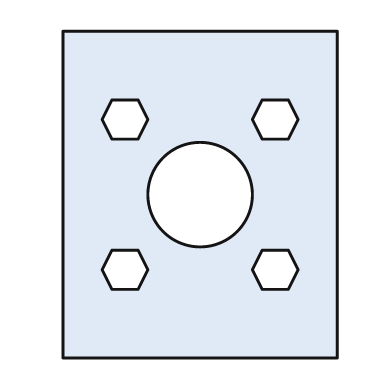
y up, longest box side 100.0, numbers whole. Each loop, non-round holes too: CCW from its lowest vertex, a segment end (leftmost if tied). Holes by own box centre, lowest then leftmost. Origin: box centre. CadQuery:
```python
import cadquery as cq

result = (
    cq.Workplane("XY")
    .moveTo(-42.0, -50.0)
    .lineTo(42.0, -50.0)
    .lineTo(42.0, 50.0)
    .lineTo(-42.0, 50.0)
    .close()
    .moveTo(-27.0, -29.0)
    .lineTo(-19.0, -29.0)
    .lineTo(-16.0, -23.0)
    .lineTo(-19.0, -17.0)
    .lineTo(-27.0, -17.0)
    .lineTo(-30.0, -23.0)
    .close()
    .moveTo(19.0, -29.0)
    .lineTo(27.0, -29.0)
    .lineTo(30.0, -23.0)
    .lineTo(27.0, -17.0)
    .lineTo(19.0, -17.0)
    .lineTo(16.0, -23.0)
    .close()
    .moveTo(0.0, 0.0)
    .circle(16.0)
    .moveTo(-27.0, 17.0)
    .lineTo(-19.0, 17.0)
    .lineTo(-16.0, 23.0)
    .lineTo(-19.0, 29.0)
    .lineTo(-27.0, 29.0)
    .lineTo(-30.0, 23.0)
    .close()
    .moveTo(19.0, 17.0)
    .lineTo(27.0, 17.0)
    .lineTo(30.0, 23.0)
    .lineTo(27.0, 29.0)
    .lineTo(19.0, 29.0)
    .lineTo(16.0, 23.0)
    .close()
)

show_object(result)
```